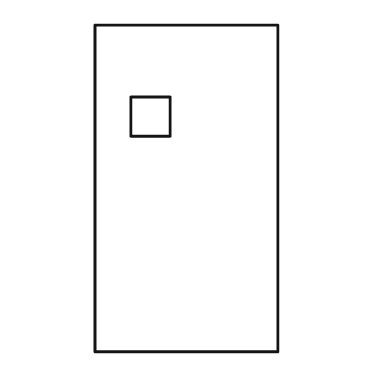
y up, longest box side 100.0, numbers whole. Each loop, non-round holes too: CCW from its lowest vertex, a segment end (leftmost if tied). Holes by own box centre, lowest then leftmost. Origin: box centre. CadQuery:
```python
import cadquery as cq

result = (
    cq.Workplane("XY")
    .moveTo(-28.0, -50.0)
    .lineTo(28.0, -50.0)
    .lineTo(28.0, 50.0)
    .lineTo(-28.0, 50.0)
    .close()
    .moveTo(-17.0, 16.0)
    .lineTo(-5.0, 16.0)
    .lineTo(-5.0, 28.0)
    .lineTo(-17.0, 28.0)
    .close()
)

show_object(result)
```